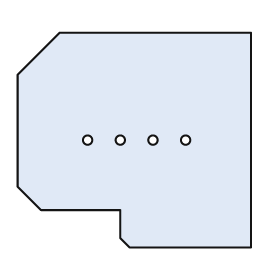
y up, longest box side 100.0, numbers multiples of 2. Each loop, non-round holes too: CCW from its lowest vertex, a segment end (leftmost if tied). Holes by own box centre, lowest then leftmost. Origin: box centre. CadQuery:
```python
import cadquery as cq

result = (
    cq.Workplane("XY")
    .moveTo(-2.0, -46.0)
    .lineTo(50.0, -46.0)
    .lineTo(50.0, 46.0)
    .lineTo(-32.0, 46.0)
    .lineTo(-50.0, 28.0)
    .lineTo(-50.0, -20.0)
    .lineTo(-40.0, -30.0)
    .lineTo(-6.0, -30.0)
    .lineTo(-6.0, -42.0)
    .close()
    .moveTo(-20.0, 0.0)
    .circle(2.0)
    .moveTo(-6.0, 0.0)
    .circle(2.0)
    .moveTo(8.0, 0.0)
    .circle(2.0)
    .moveTo(22.0, 0.0)
    .circle(2.0)
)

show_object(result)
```